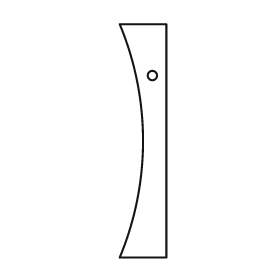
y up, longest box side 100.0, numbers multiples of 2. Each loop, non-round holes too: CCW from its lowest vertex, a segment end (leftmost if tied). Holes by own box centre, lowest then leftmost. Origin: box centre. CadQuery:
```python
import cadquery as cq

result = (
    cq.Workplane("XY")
    .moveTo(-10.0, -50.0)
    .lineTo(10.0, -50.0)
    .lineTo(10.0, 50.0)
    .lineTo(-10.0, 50.0)
    .threePointArc((0.0, 0.0), (-10.0, -50.0))
    .close()
    .moveTo(4.0, 28.0)
    .circle(2.0)
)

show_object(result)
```